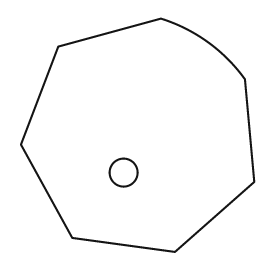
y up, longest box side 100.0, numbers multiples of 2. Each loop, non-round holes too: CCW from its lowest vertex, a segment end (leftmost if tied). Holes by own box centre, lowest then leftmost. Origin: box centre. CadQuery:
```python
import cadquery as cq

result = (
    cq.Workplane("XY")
    .moveTo(16.0, -50.0)
    .lineTo(50.0, -20.0)
    .lineTo(46.0, 24.0)
    .threePointArc((30.0, 40.0), (10.0, 50.0))
    .lineTo(-34.0, 38.0)
    .lineTo(-50.0, -4.0)
    .lineTo(-28.0, -44.0)
    .close()
    .moveTo(-6.0, -16.0)
    .circle(6.0)
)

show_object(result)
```